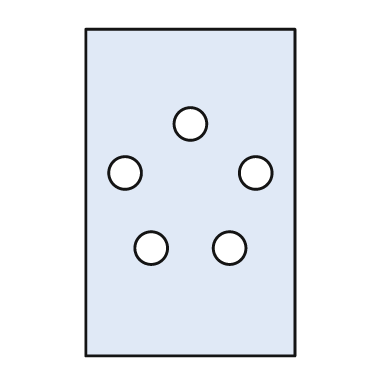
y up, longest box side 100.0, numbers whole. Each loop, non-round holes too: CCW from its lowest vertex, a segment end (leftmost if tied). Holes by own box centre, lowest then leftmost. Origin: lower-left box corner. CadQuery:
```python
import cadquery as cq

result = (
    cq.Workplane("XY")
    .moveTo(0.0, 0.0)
    .lineTo(64.0, 0.0)
    .lineTo(64.0, 100.0)
    .lineTo(0.0, 100.0)
    .close()
    .moveTo(20.0, 33.0)
    .circle(5.0)
    .moveTo(44.0, 33.0)
    .circle(5.0)
    .moveTo(12.0, 56.0)
    .circle(5.0)
    .moveTo(52.0, 56.0)
    .circle(5.0)
    .moveTo(32.0, 71.0)
    .circle(5.0)
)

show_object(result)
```